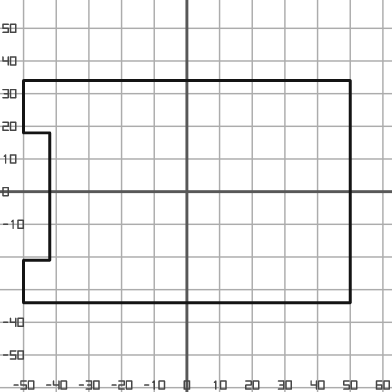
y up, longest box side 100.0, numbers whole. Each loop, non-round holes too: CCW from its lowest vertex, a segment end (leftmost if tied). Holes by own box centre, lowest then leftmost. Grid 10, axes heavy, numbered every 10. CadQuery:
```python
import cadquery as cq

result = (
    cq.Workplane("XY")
    .moveTo(-50.0, -34.0)
    .lineTo(50.0, -34.0)
    .lineTo(50.0, 34.0)
    .lineTo(-50.0, 34.0)
    .lineTo(-50.0, 18.0)
    .lineTo(-42.0, 18.0)
    .lineTo(-42.0, -21.0)
    .lineTo(-50.0, -21.0)
    .close()
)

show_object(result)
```